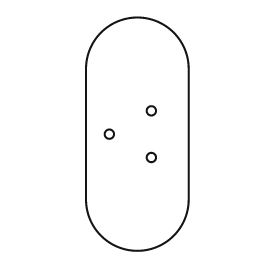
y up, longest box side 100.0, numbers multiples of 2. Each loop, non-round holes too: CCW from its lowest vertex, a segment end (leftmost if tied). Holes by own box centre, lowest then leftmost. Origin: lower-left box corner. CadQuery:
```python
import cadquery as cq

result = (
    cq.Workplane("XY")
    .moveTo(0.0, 22.0)
    .threePointArc((22.0, 0.0), (44.0, 22.0))
    .lineTo(44.0, 78.0)
    .threePointArc((22.0, 100.0), (0.0, 78.0))
    .close()
    .moveTo(28.0, 40.0)
    .circle(2.0)
    .moveTo(10.0, 50.0)
    .circle(2.0)
    .moveTo(28.0, 60.0)
    .circle(2.0)
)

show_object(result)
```